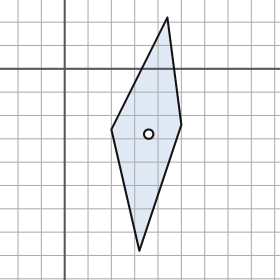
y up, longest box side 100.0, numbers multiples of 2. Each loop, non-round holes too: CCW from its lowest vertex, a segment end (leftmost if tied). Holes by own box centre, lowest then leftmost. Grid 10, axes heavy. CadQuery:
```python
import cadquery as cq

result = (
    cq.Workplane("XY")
    .moveTo(32.0, -78.0)
    .lineTo(50.0, -24.0)
    .lineTo(44.0, 22.0)
    .lineTo(20.0, -26.0)
    .close()
    .moveTo(36.0, -28.0)
    .circle(2.0)
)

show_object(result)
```